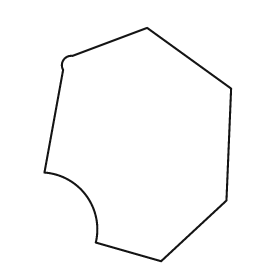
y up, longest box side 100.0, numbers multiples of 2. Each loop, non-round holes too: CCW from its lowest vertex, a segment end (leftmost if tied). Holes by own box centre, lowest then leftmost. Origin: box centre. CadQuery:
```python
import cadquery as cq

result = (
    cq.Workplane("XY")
    .moveTo(10.0, -50.0)
    .lineTo(38.0, -24.0)
    .lineTo(40.0, 24.0)
    .lineTo(4.0, 50.0)
    .lineTo(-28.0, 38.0)
    .threePointArc((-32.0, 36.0), (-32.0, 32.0))
    .lineTo(-40.0, -12.0)
    .threePointArc((-22.0, -22.0), (-18.0, -42.0))
    .close()
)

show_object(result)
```